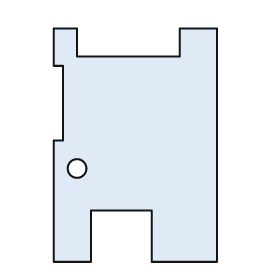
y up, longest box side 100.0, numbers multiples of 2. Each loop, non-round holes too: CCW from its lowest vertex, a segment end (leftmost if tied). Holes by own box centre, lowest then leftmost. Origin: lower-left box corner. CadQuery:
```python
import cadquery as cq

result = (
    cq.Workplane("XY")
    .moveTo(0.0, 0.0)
    .lineTo(16.0, 0.0)
    .lineTo(16.0, 22.0)
    .lineTo(42.0, 22.0)
    .lineTo(42.0, 0.0)
    .lineTo(70.0, 0.0)
    .lineTo(70.0, 100.0)
    .lineTo(54.0, 100.0)
    .lineTo(54.0, 88.0)
    .lineTo(10.0, 88.0)
    .lineTo(10.0, 100.0)
    .lineTo(0.0, 100.0)
    .lineTo(0.0, 84.0)
    .lineTo(4.0, 84.0)
    .lineTo(4.0, 52.0)
    .lineTo(0.0, 52.0)
    .close()
    .moveTo(10.0, 40.0)
    .circle(4.0)
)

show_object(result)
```